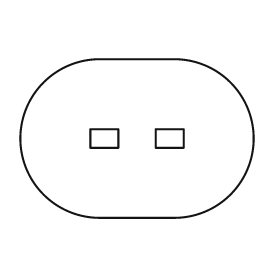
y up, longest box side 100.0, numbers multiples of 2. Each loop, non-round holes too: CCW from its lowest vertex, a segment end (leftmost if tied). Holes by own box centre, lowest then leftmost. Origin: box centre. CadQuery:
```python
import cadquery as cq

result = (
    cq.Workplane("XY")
    .moveTo(-16.0, -34.0)
    .lineTo(16.0, -34.0)
    .threePointArc((50.0, 0.0), (16.0, 34.0))
    .lineTo(-16.0, 34.0)
    .threePointArc((-50.0, 0.0), (-16.0, -34.0))
    .close()
    .moveTo(-20.0, -4.0)
    .lineTo(-8.0, -4.0)
    .lineTo(-8.0, 4.0)
    .lineTo(-20.0, 4.0)
    .close()
    .moveTo(8.0, -4.0)
    .lineTo(20.0, -4.0)
    .lineTo(20.0, 4.0)
    .lineTo(8.0, 4.0)
    .close()
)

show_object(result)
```